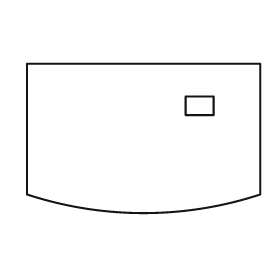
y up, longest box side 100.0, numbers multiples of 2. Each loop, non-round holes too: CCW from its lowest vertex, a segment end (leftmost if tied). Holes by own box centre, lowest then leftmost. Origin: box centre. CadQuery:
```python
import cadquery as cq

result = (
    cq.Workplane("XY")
    .moveTo(-50.0, -24.0)
    .threePointArc((0.0, -32.0), (50.0, -24.0))
    .lineTo(50.0, 32.0)
    .lineTo(-50.0, 32.0)
    .close()
    .moveTo(18.0, 10.0)
    .lineTo(30.0, 10.0)
    .lineTo(30.0, 18.0)
    .lineTo(18.0, 18.0)
    .close()
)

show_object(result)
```